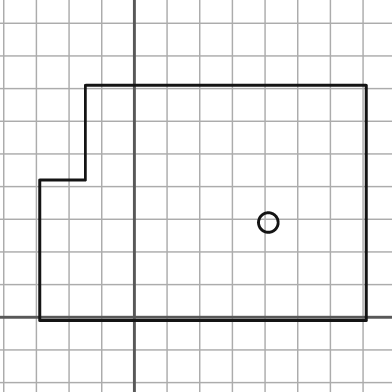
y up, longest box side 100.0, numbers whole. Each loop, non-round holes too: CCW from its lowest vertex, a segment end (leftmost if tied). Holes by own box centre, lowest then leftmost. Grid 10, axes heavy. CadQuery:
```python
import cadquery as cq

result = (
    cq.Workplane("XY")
    .moveTo(-29.0, -1.0)
    .lineTo(71.0, -1.0)
    .lineTo(71.0, 71.0)
    .lineTo(-15.0, 71.0)
    .lineTo(-15.0, 42.0)
    .lineTo(-29.0, 42.0)
    .close()
    .moveTo(41.0, 29.0)
    .circle(3.0)
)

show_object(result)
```